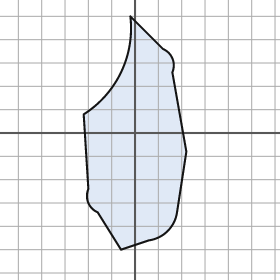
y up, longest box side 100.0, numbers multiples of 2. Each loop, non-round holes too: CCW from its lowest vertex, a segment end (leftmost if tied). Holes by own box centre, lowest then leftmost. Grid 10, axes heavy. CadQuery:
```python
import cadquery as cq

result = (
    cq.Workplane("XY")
    .moveTo(-6.0, -50.0)
    .lineTo(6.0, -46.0)
    .threePointArc((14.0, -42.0), (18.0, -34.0))
    .lineTo(22.0, -8.0)
    .lineTo(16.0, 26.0)
    .threePointArc((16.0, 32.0), (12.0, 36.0))
    .lineTo(-2.0, 50.0)
    .threePointArc((-6.0, 26.0), (-22.0, 8.0))
    .lineTo(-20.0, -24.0)
    .threePointArc((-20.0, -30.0), (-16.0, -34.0))
    .close()
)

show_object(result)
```